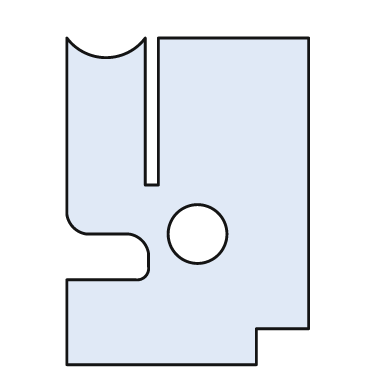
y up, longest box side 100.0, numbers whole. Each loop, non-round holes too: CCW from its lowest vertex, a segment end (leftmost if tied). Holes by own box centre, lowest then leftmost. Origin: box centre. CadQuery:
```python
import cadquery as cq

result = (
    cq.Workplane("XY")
    .moveTo(-37.0, -50.0)
    .lineTo(21.0, -50.0)
    .lineTo(21.0, -39.0)
    .lineTo(37.0, -39.0)
    .lineTo(37.0, 50.0)
    .lineTo(-9.0, 50.0)
    .lineTo(-9.0, 5.0)
    .lineTo(-13.0, 5.0)
    .lineTo(-13.0, 50.0)
    .threePointArc((-25.0, 44.0), (-37.0, 50.0))
    .lineTo(-37.0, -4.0)
    .threePointArc((-35.0, -8.0), (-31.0, -10.0))
    .lineTo(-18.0, -10.0)
    .threePointArc((-14.0, -12.0), (-12.0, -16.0))
    .lineTo(-12.0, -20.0)
    .threePointArc((-13.0, -23.0), (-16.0, -24.0))
    .lineTo(-37.0, -24.0)
    .close()
    .moveTo(3.0, -10.0)
    .circle(9.0)
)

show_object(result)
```